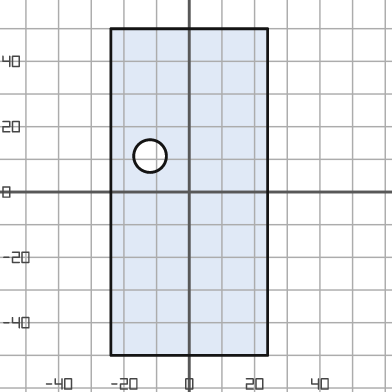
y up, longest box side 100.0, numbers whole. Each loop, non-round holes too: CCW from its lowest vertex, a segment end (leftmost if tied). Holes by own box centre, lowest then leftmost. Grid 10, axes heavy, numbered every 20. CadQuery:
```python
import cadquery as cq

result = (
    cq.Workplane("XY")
    .moveTo(-24.0, -50.0)
    .lineTo(24.0, -50.0)
    .lineTo(24.0, 50.0)
    .lineTo(-24.0, 50.0)
    .close()
    .moveTo(-12.0, 11.0)
    .circle(5.0)
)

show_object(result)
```